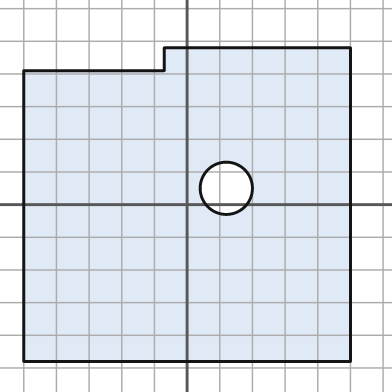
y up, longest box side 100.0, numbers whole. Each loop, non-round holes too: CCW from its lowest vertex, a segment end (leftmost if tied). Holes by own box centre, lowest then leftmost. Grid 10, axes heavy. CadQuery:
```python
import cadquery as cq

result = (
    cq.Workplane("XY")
    .moveTo(-50.0, -48.0)
    .lineTo(50.0, -48.0)
    .lineTo(50.0, 48.0)
    .lineTo(-7.0, 48.0)
    .lineTo(-7.0, 41.0)
    .lineTo(-50.0, 41.0)
    .close()
    .moveTo(12.0, 5.0)
    .circle(8.0)
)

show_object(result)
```